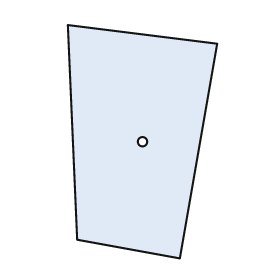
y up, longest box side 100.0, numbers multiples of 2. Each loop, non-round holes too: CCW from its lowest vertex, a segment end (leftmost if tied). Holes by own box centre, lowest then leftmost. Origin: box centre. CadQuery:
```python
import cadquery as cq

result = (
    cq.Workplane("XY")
    .moveTo(16.0, -50.0)
    .lineTo(32.0, 42.0)
    .lineTo(-32.0, 50.0)
    .lineTo(-28.0, -42.0)
    .close()
    .moveTo(0.0, 0.0)
    .circle(2.0)
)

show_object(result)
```